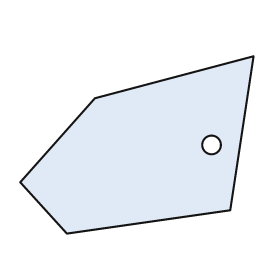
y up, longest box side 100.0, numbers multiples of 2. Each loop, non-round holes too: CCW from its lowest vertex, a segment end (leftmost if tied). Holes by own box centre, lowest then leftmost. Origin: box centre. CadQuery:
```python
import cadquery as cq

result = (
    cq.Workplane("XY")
    .moveTo(-30.0, -38.0)
    .lineTo(40.0, -28.0)
    .lineTo(50.0, 38.0)
    .lineTo(-18.0, 20.0)
    .lineTo(-50.0, -16.0)
    .close()
    .moveTo(32.0, 0.0)
    .circle(4.0)
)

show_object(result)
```